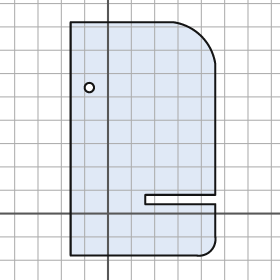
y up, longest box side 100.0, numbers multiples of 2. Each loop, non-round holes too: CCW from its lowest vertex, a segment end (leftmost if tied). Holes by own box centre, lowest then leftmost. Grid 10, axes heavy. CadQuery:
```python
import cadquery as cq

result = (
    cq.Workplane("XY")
    .moveTo(-16.0, -18.0)
    .lineTo(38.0, -18.0)
    .threePointArc((44.0, -16.0), (46.0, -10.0))
    .lineTo(46.0, 4.0)
    .lineTo(16.0, 4.0)
    .lineTo(16.0, 8.0)
    .lineTo(46.0, 8.0)
    .lineTo(46.0, 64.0)
    .threePointArc((40.0, 76.0), (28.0, 82.0))
    .lineTo(-16.0, 82.0)
    .close()
    .moveTo(-8.0, 54.0)
    .circle(2.0)
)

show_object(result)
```